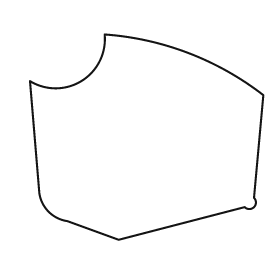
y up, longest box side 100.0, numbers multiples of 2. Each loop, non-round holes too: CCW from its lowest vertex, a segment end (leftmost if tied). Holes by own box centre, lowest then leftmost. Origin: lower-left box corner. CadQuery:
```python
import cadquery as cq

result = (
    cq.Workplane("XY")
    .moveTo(38.0, 0.0)
    .lineTo(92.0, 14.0)
    .threePointArc((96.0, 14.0), (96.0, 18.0))
    .lineTo(100.0, 62.0)
    .threePointArc((68.0, 80.0), (32.0, 88.0))
    .threePointArc((22.0, 68.0), (0.0, 68.0))
    .lineTo(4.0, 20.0)
    .threePointArc((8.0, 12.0), (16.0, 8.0))
    .close()
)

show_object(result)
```